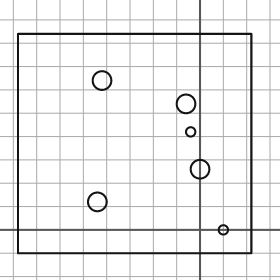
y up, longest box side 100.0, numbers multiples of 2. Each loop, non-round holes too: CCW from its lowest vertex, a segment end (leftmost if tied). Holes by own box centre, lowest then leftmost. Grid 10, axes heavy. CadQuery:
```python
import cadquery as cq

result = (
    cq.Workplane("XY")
    .moveTo(-78.0, -10.0)
    .lineTo(22.0, -10.0)
    .lineTo(22.0, 84.0)
    .lineTo(-78.0, 84.0)
    .close()
    .moveTo(10.0, 0.0)
    .circle(2.0)
    .moveTo(-44.0, 12.0)
    .circle(4.0)
    .moveTo(0.0, 26.0)
    .circle(4.0)
    .moveTo(-4.0, 42.0)
    .circle(2.0)
    .moveTo(-6.0, 54.0)
    .circle(4.0)
    .moveTo(-42.0, 64.0)
    .circle(4.0)
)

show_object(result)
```